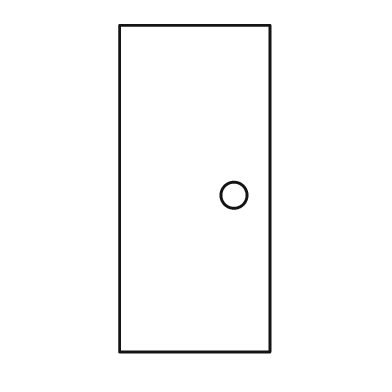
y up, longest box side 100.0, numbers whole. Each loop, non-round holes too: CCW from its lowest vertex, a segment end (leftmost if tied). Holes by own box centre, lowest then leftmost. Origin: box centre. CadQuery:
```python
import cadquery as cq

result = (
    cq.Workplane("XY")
    .moveTo(-23.0, -50.0)
    .lineTo(23.0, -50.0)
    .lineTo(23.0, 50.0)
    .lineTo(-23.0, 50.0)
    .close()
    .moveTo(12.0, -2.0)
    .circle(4.0)
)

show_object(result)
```